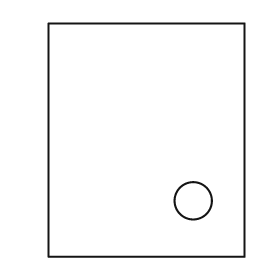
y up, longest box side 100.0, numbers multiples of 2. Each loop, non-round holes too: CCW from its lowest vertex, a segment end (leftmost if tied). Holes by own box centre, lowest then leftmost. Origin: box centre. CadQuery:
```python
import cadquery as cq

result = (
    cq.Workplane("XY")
    .moveTo(-42.0, -50.0)
    .lineTo(42.0, -50.0)
    .lineTo(42.0, 50.0)
    .lineTo(-42.0, 50.0)
    .close()
    .moveTo(20.0, -26.0)
    .circle(8.0)
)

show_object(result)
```